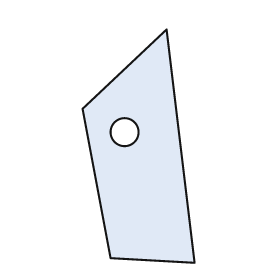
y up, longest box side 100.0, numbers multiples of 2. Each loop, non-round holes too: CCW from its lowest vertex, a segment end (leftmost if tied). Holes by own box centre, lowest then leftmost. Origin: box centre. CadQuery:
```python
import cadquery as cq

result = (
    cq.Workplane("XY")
    .moveTo(24.0, -50.0)
    .lineTo(12.0, 50.0)
    .lineTo(-24.0, 16.0)
    .lineTo(-12.0, -48.0)
    .close()
    .moveTo(-6.0, 6.0)
    .circle(6.0)
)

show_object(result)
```